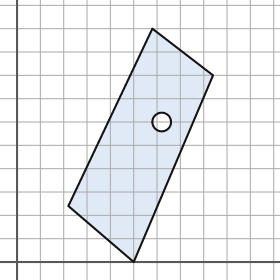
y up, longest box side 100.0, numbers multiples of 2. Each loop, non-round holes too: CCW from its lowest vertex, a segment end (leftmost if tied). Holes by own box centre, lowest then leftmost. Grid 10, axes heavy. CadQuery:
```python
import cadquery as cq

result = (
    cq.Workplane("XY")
    .moveTo(50.0, 0.0)
    .lineTo(84.0, 80.0)
    .lineTo(58.0, 100.0)
    .lineTo(22.0, 24.0)
    .close()
    .moveTo(62.0, 60.0)
    .circle(4.0)
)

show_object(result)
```